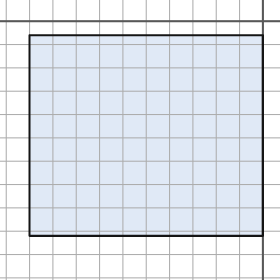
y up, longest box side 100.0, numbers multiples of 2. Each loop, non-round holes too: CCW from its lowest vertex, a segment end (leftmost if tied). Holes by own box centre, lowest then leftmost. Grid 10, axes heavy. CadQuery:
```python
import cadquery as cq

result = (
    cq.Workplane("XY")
    .moveTo(-100.0, -92.0)
    .lineTo(0.0, -92.0)
    .lineTo(0.0, -6.0)
    .lineTo(-100.0, -6.0)
    .close()
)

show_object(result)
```